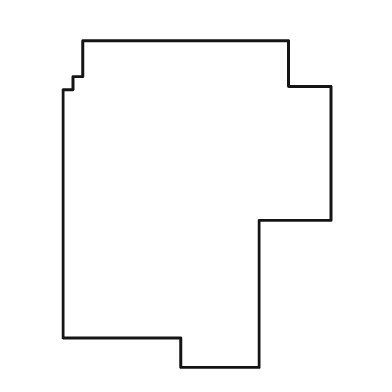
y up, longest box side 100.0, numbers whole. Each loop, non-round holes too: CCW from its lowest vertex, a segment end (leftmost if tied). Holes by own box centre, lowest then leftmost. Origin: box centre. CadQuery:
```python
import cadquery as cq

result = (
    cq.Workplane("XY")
    .moveTo(-5.0, -50.0)
    .lineTo(19.0, -50.0)
    .lineTo(19.0, -5.0)
    .lineTo(41.0, -5.0)
    .lineTo(41.0, 36.0)
    .lineTo(28.0, 36.0)
    .lineTo(28.0, 50.0)
    .lineTo(-35.0, 50.0)
    .lineTo(-35.0, 39.0)
    .lineTo(-38.0, 39.0)
    .lineTo(-38.0, 35.0)
    .lineTo(-41.0, 35.0)
    .lineTo(-41.0, -41.0)
    .lineTo(-5.0, -41.0)
    .close()
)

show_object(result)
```